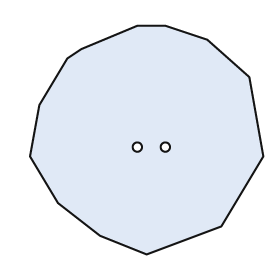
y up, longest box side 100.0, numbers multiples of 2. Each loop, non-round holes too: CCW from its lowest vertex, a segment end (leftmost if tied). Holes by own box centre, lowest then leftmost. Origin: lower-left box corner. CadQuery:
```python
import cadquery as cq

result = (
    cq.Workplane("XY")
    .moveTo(50.0, 0.0)
    .lineTo(82.0, 12.0)
    .lineTo(100.0, 42.0)
    .lineTo(94.0, 76.0)
    .lineTo(76.0, 92.0)
    .lineTo(58.0, 98.0)
    .lineTo(46.0, 98.0)
    .lineTo(22.0, 88.0)
    .lineTo(16.0, 84.0)
    .lineTo(4.0, 64.0)
    .lineTo(0.0, 42.0)
    .lineTo(12.0, 22.0)
    .lineTo(30.0, 8.0)
    .close()
    .moveTo(46.0, 46.0)
    .circle(2.0)
    .moveTo(58.0, 46.0)
    .circle(2.0)
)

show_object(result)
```